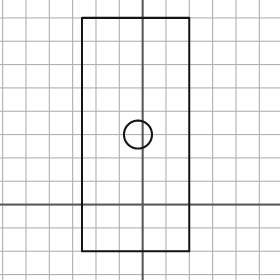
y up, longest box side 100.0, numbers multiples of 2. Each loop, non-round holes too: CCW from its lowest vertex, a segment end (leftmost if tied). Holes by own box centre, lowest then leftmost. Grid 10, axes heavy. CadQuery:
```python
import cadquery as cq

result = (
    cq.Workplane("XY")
    .moveTo(-26.0, -20.0)
    .lineTo(20.0, -20.0)
    .lineTo(20.0, 80.0)
    .lineTo(-26.0, 80.0)
    .close()
    .moveTo(-2.0, 30.0)
    .circle(6.0)
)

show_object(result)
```